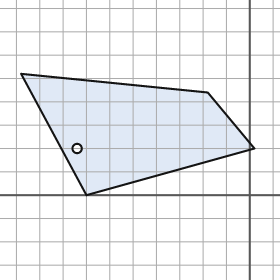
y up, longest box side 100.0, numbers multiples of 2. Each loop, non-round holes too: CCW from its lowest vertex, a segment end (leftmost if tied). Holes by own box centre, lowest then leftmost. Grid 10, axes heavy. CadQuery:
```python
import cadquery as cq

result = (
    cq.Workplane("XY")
    .moveTo(-70.0, 0.0)
    .lineTo(2.0, 20.0)
    .lineTo(-18.0, 44.0)
    .lineTo(-98.0, 52.0)
    .close()
    .moveTo(-74.0, 20.0)
    .circle(2.0)
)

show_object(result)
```